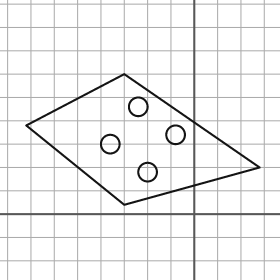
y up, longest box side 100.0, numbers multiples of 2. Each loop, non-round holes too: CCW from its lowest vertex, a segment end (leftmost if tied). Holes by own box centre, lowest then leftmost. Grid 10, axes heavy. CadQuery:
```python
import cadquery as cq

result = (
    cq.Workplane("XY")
    .moveTo(-30.0, 4.0)
    .lineTo(28.0, 20.0)
    .lineTo(-30.0, 60.0)
    .lineTo(-72.0, 38.0)
    .close()
    .moveTo(-20.0, 18.0)
    .circle(4.0)
    .moveTo(-36.0, 30.0)
    .circle(4.0)
    .moveTo(-8.0, 34.0)
    .circle(4.0)
    .moveTo(-24.0, 46.0)
    .circle(4.0)
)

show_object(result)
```